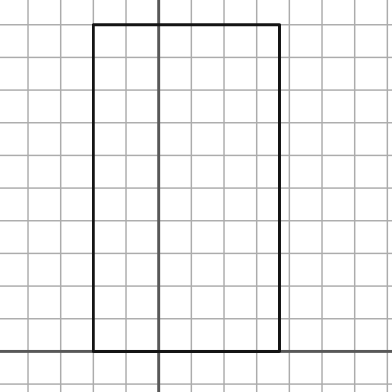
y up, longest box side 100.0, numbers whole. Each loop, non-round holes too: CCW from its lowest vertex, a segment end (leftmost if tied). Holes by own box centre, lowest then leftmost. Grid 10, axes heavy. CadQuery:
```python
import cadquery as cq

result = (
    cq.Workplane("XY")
    .moveTo(-20.0, 0.0)
    .lineTo(37.0, 0.0)
    .lineTo(37.0, 100.0)
    .lineTo(-20.0, 100.0)
    .close()
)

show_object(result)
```